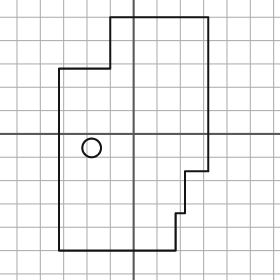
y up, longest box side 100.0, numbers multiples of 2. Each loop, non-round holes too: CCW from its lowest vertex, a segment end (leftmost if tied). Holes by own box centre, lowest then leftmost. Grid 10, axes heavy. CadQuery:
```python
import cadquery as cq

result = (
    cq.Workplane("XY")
    .moveTo(-32.0, -50.0)
    .lineTo(18.0, -50.0)
    .lineTo(18.0, -34.0)
    .lineTo(22.0, -34.0)
    .lineTo(22.0, -16.0)
    .lineTo(32.0, -16.0)
    .lineTo(32.0, 50.0)
    .lineTo(-10.0, 50.0)
    .lineTo(-10.0, 28.0)
    .lineTo(-32.0, 28.0)
    .close()
    .moveTo(-18.0, -6.0)
    .circle(4.0)
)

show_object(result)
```